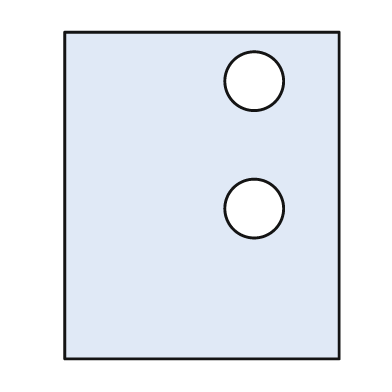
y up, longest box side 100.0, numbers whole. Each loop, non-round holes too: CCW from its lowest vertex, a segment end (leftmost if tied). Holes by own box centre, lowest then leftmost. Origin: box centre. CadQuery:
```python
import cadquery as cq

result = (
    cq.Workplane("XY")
    .moveTo(-42.0, -50.0)
    .lineTo(42.0, -50.0)
    .lineTo(42.0, 50.0)
    .lineTo(-42.0, 50.0)
    .close()
    .moveTo(16.0, -4.0)
    .circle(9.0)
    .moveTo(16.0, 35.0)
    .circle(9.0)
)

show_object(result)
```